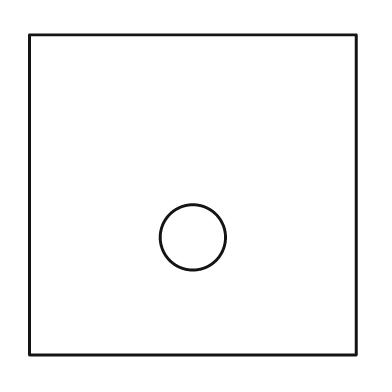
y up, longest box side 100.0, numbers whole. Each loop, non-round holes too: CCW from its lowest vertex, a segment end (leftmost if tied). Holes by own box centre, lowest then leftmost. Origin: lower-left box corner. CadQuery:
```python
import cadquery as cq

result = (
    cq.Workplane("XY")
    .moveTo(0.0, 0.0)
    .lineTo(100.0, 0.0)
    .lineTo(100.0, 98.0)
    .lineTo(0.0, 98.0)
    .close()
    .moveTo(50.0, 36.0)
    .circle(10.0)
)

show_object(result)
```